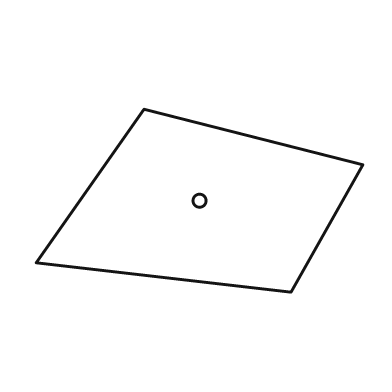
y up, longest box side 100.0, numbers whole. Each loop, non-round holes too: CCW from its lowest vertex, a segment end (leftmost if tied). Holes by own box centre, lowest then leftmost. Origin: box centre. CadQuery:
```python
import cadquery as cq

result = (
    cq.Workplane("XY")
    .moveTo(28.0, -28.0)
    .lineTo(50.0, 11.0)
    .lineTo(-17.0, 28.0)
    .lineTo(-50.0, -19.0)
    .close()
    .moveTo(0.0, 0.0)
    .circle(2.0)
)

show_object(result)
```